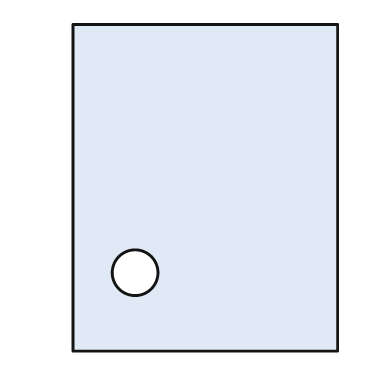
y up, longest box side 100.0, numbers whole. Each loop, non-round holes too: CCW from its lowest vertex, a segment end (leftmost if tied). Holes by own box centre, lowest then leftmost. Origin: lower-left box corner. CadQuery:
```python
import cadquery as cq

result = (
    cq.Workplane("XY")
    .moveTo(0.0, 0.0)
    .lineTo(81.0, 0.0)
    .lineTo(81.0, 100.0)
    .lineTo(0.0, 100.0)
    .close()
    .moveTo(19.0, 24.0)
    .circle(7.0)
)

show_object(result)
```